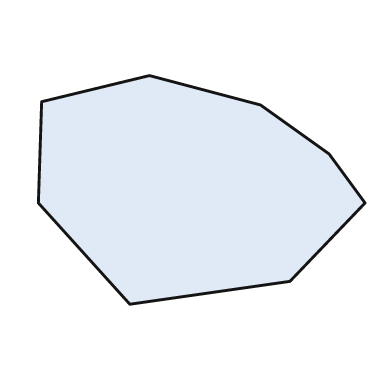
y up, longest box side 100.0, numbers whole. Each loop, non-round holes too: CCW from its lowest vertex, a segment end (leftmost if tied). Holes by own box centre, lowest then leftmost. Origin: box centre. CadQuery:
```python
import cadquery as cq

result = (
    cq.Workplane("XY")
    .moveTo(-22.0, -35.0)
    .lineTo(27.0, -28.0)
    .lineTo(50.0, -4.0)
    .lineTo(39.0, 11.0)
    .lineTo(18.0, 26.0)
    .lineTo(-16.0, 35.0)
    .lineTo(-49.0, 27.0)
    .lineTo(-50.0, -4.0)
    .close()
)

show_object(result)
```